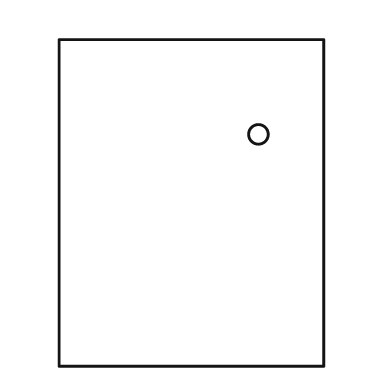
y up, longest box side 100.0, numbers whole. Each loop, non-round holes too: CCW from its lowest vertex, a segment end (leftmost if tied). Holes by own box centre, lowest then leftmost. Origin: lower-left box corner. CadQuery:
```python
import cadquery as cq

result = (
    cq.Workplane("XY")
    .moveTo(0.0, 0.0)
    .lineTo(81.0, 0.0)
    .lineTo(81.0, 100.0)
    .lineTo(0.0, 100.0)
    .close()
    .moveTo(61.0, 71.0)
    .circle(3.0)
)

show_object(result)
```